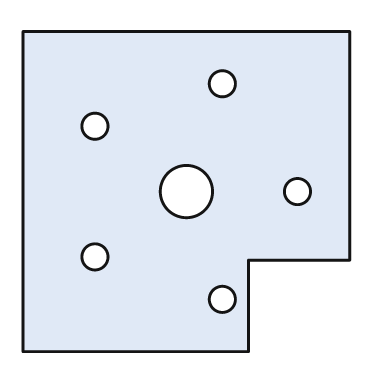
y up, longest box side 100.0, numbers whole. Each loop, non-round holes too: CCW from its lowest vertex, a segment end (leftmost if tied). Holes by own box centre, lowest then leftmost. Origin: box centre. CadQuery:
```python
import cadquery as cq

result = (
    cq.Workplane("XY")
    .moveTo(-50.0, -49.0)
    .lineTo(19.0, -49.0)
    .lineTo(19.0, -21.0)
    .lineTo(50.0, -21.0)
    .lineTo(50.0, 49.0)
    .lineTo(-50.0, 49.0)
    .close()
    .moveTo(11.0, -33.0)
    .circle(4.0)
    .moveTo(-28.0, -20.0)
    .circle(4.0)
    .moveTo(0.0, 0.0)
    .circle(8.0)
    .moveTo(34.0, 0.0)
    .circle(4.0)
    .moveTo(-28.0, 20.0)
    .circle(4.0)
    .moveTo(11.0, 33.0)
    .circle(4.0)
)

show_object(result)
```